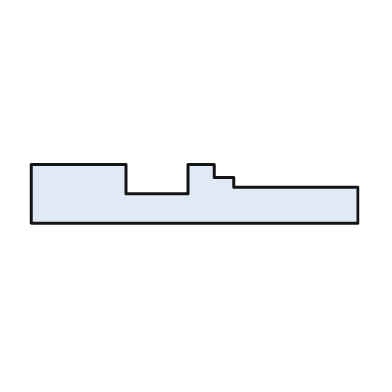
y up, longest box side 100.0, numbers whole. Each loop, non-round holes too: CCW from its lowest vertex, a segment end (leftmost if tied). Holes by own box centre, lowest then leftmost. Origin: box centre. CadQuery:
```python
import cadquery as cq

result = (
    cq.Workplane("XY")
    .moveTo(-50.0, -9.0)
    .lineTo(50.0, -9.0)
    .lineTo(50.0, 2.0)
    .lineTo(12.0, 2.0)
    .lineTo(12.0, 5.0)
    .lineTo(6.0, 5.0)
    .lineTo(6.0, 9.0)
    .lineTo(-2.0, 9.0)
    .lineTo(-2.0, 0.0)
    .lineTo(-21.0, 0.0)
    .lineTo(-21.0, 9.0)
    .lineTo(-50.0, 9.0)
    .close()
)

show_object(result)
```